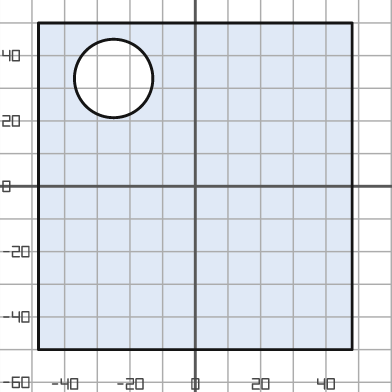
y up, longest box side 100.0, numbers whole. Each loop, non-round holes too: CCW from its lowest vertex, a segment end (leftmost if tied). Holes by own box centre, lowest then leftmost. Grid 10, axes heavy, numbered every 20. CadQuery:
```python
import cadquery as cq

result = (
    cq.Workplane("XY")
    .moveTo(-48.0, -50.0)
    .lineTo(48.0, -50.0)
    .lineTo(48.0, 50.0)
    .lineTo(-48.0, 50.0)
    .close()
    .moveTo(-25.0, 33.0)
    .circle(12.0)
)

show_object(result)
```